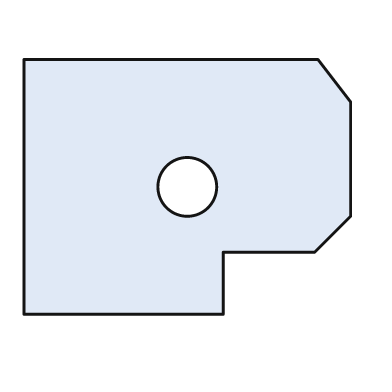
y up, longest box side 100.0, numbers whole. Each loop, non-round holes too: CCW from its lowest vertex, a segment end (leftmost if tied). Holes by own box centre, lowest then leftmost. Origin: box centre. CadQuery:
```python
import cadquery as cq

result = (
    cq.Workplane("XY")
    .moveTo(-50.0, -39.0)
    .lineTo(11.0, -39.0)
    .lineTo(11.0, -20.0)
    .lineTo(39.0, -20.0)
    .lineTo(50.0, -9.0)
    .lineTo(50.0, 26.0)
    .lineTo(40.0, 39.0)
    .lineTo(-50.0, 39.0)
    .close()
    .moveTo(0.0, 0.0)
    .circle(9.0)
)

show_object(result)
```